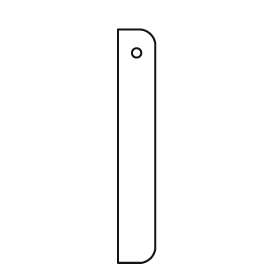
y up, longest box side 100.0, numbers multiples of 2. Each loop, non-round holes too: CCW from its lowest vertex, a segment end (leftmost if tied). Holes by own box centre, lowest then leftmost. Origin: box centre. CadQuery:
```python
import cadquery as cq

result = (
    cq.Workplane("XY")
    .moveTo(-8.0, -50.0)
    .lineTo(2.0, -50.0)
    .threePointArc((6.0, -48.0), (8.0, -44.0))
    .lineTo(8.0, 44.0)
    .threePointArc((6.0, 48.0), (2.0, 50.0))
    .lineTo(-8.0, 50.0)
    .close()
    .moveTo(0.0, 40.0)
    .circle(2.0)
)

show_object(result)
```